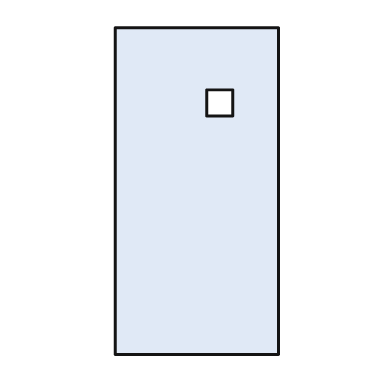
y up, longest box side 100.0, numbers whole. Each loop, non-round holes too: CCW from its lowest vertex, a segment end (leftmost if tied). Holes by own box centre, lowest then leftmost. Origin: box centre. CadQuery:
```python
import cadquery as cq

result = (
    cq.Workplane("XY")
    .moveTo(-25.0, -50.0)
    .lineTo(25.0, -50.0)
    .lineTo(25.0, 50.0)
    .lineTo(-25.0, 50.0)
    .close()
    .moveTo(3.0, 23.0)
    .lineTo(11.0, 23.0)
    .lineTo(11.0, 31.0)
    .lineTo(3.0, 31.0)
    .close()
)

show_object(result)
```